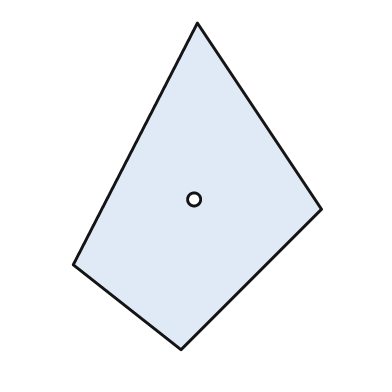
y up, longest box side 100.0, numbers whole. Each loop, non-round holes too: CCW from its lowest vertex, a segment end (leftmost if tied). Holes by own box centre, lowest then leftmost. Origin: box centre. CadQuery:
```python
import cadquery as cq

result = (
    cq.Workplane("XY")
    .moveTo(-5.0, -50.0)
    .lineTo(38.0, -7.0)
    .lineTo(0.0, 50.0)
    .lineTo(-38.0, -24.0)
    .close()
    .moveTo(-1.0, -4.0)
    .circle(2.0)
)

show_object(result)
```